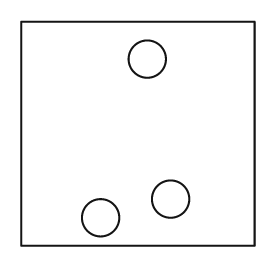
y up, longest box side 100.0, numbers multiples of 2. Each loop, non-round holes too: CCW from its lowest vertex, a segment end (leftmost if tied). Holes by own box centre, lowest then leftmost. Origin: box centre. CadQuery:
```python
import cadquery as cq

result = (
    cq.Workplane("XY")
    .moveTo(-50.0, -48.0)
    .lineTo(50.0, -48.0)
    .lineTo(50.0, 48.0)
    .lineTo(-50.0, 48.0)
    .close()
    .moveTo(-16.0, -36.0)
    .circle(8.0)
    .moveTo(14.0, -28.0)
    .circle(8.0)
    .moveTo(4.0, 32.0)
    .circle(8.0)
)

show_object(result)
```